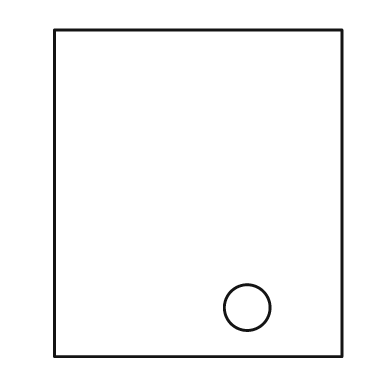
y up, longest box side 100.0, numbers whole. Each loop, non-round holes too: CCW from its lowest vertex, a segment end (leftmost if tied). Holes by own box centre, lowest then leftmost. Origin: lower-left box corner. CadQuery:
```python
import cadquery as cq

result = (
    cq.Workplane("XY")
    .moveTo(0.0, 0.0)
    .lineTo(88.0, 0.0)
    .lineTo(88.0, 100.0)
    .lineTo(0.0, 100.0)
    .close()
    .moveTo(59.0, 15.0)
    .circle(7.0)
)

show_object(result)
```